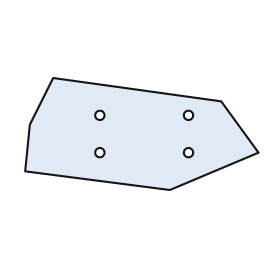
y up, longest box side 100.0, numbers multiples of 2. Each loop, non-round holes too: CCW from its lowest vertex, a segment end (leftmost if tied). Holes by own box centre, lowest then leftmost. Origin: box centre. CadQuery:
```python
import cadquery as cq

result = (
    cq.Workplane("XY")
    .moveTo(12.0, -24.0)
    .lineTo(50.0, -8.0)
    .lineTo(34.0, 14.0)
    .lineTo(-38.0, 24.0)
    .lineTo(-48.0, 4.0)
    .lineTo(-50.0, -16.0)
    .close()
    .moveTo(-18.0, -8.0)
    .circle(2.0)
    .moveTo(20.0, -8.0)
    .circle(2.0)
    .moveTo(-18.0, 8.0)
    .circle(2.0)
    .moveTo(20.0, 8.0)
    .circle(2.0)
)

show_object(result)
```